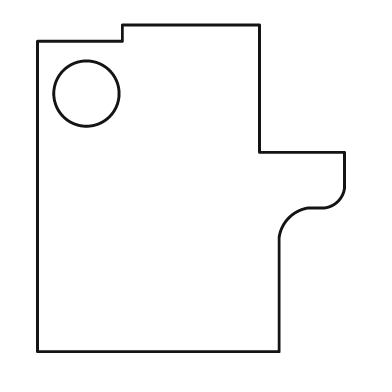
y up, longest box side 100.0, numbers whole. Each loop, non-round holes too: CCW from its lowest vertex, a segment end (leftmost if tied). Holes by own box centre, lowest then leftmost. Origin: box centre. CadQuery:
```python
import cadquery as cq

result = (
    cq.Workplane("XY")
    .moveTo(-47.0, -50.0)
    .lineTo(27.0, -50.0)
    .lineTo(27.0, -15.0)
    .threePointArc((30.0, -9.0), (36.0, -6.0))
    .lineTo(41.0, -6.0)
    .threePointArc((45.0, -4.0), (47.0, 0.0))
    .lineTo(47.0, 11.0)
    .lineTo(21.0, 11.0)
    .lineTo(21.0, 50.0)
    .lineTo(-21.0, 50.0)
    .lineTo(-21.0, 45.0)
    .lineTo(-47.0, 45.0)
    .close()
    .moveTo(-32.0, 29.0)
    .circle(10.0)
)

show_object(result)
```